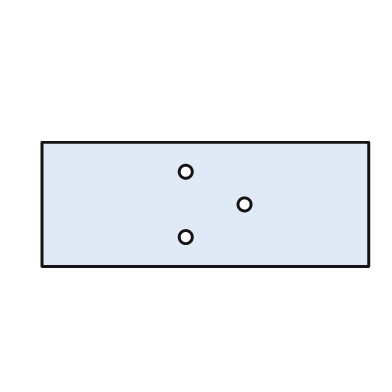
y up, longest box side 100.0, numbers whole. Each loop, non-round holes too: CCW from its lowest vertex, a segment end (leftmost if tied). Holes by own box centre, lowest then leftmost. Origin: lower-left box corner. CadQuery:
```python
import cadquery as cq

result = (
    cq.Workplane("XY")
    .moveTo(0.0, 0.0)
    .lineTo(100.0, 0.0)
    .lineTo(100.0, 38.0)
    .lineTo(0.0, 38.0)
    .close()
    .moveTo(44.0, 9.0)
    .circle(2.0)
    .moveTo(62.0, 19.0)
    .circle(2.0)
    .moveTo(44.0, 29.0)
    .circle(2.0)
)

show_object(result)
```